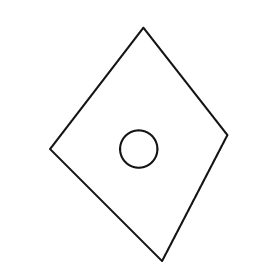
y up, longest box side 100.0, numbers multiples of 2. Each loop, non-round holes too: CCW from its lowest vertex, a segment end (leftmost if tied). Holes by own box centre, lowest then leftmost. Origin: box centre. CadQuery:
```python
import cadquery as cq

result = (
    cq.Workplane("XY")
    .moveTo(10.0, -50.0)
    .lineTo(38.0, 4.0)
    .lineTo(2.0, 50.0)
    .lineTo(-38.0, -2.0)
    .close()
    .moveTo(0.0, -2.0)
    .circle(8.0)
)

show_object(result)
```